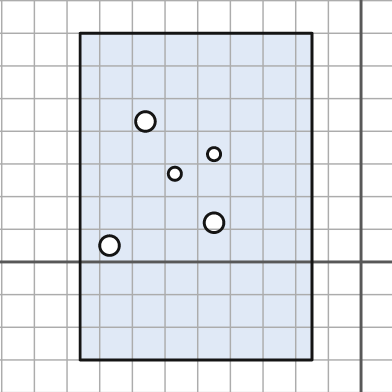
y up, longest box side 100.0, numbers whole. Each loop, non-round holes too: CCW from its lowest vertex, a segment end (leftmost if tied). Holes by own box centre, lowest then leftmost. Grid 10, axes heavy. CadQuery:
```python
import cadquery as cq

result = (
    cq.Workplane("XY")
    .moveTo(-86.0, -30.0)
    .lineTo(-15.0, -30.0)
    .lineTo(-15.0, 70.0)
    .lineTo(-86.0, 70.0)
    .close()
    .moveTo(-77.0, 5.0)
    .circle(3.0)
    .moveTo(-45.0, 12.0)
    .circle(3.0)
    .moveTo(-57.0, 27.0)
    .circle(2.0)
    .moveTo(-45.0, 33.0)
    .circle(2.0)
    .moveTo(-66.0, 43.0)
    .circle(3.0)
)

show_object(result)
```